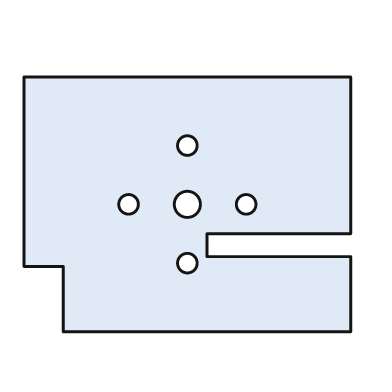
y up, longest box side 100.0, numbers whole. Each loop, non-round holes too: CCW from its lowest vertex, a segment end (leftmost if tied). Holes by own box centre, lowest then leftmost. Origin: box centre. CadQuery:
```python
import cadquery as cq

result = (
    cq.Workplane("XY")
    .moveTo(-38.0, -39.0)
    .lineTo(50.0, -39.0)
    .lineTo(50.0, -16.0)
    .lineTo(6.0, -16.0)
    .lineTo(6.0, -9.0)
    .lineTo(50.0, -9.0)
    .lineTo(50.0, 39.0)
    .lineTo(-50.0, 39.0)
    .lineTo(-50.0, -19.0)
    .lineTo(-38.0, -19.0)
    .close()
    .moveTo(0.0, -18.0)
    .circle(3.0)
    .moveTo(-18.0, 0.0)
    .circle(3.0)
    .moveTo(0.0, 0.0)
    .circle(4.0)
    .moveTo(18.0, 0.0)
    .circle(3.0)
    .moveTo(0.0, 18.0)
    .circle(3.0)
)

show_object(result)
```